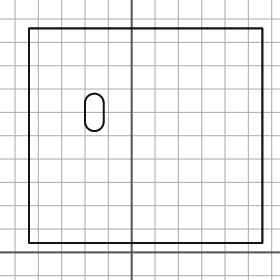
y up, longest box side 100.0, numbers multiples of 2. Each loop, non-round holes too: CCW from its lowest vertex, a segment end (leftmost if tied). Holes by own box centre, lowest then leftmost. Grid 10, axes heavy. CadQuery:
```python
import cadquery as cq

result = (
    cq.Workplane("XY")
    .moveTo(-44.0, 4.0)
    .lineTo(56.0, 4.0)
    .lineTo(56.0, 96.0)
    .lineTo(-44.0, 96.0)
    .close()
    .moveTo(-20.0, 56.0)
    .threePointArc((-16.0, 52.0), (-12.0, 56.0))
    .lineTo(-12.0, 64.0)
    .threePointArc((-16.0, 68.0), (-20.0, 64.0))
    .close()
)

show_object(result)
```